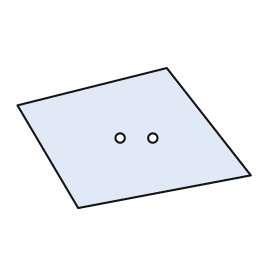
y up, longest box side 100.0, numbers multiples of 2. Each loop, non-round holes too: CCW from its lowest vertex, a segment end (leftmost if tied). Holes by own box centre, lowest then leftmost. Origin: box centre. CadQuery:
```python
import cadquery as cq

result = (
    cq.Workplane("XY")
    .moveTo(-24.0, -30.0)
    .lineTo(50.0, -16.0)
    .lineTo(14.0, 30.0)
    .lineTo(-50.0, 14.0)
    .close()
    .moveTo(-6.0, 0.0)
    .circle(2.0)
    .moveTo(8.0, 0.0)
    .circle(2.0)
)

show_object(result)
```